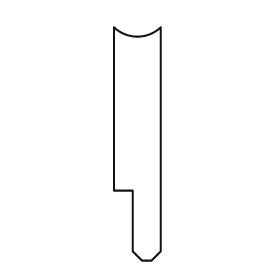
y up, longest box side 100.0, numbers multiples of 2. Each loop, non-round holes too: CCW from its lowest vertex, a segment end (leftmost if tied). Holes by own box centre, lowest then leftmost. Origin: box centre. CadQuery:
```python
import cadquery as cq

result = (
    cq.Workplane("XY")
    .moveTo(2.0, -50.0)
    .lineTo(6.0, -50.0)
    .lineTo(10.0, -46.0)
    .lineTo(10.0, 50.0)
    .threePointArc((0.0, 46.0), (-10.0, 50.0))
    .lineTo(-10.0, -20.0)
    .lineTo(-2.0, -20.0)
    .lineTo(-2.0, -46.0)
    .close()
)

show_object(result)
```